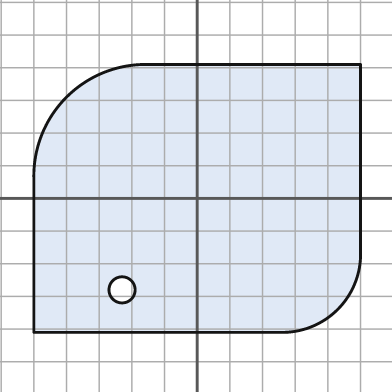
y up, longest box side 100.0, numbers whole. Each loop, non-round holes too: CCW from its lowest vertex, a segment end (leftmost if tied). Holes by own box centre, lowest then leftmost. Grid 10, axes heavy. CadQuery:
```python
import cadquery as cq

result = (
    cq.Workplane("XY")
    .moveTo(-50.0, -41.0)
    .lineTo(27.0, -41.0)
    .threePointArc((43.0, -34.0), (50.0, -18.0))
    .lineTo(50.0, 41.0)
    .lineTo(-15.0, 41.0)
    .threePointArc((-40.0, 31.0), (-50.0, 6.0))
    .close()
    .moveTo(-23.0, -28.0)
    .circle(4.0)
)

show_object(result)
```